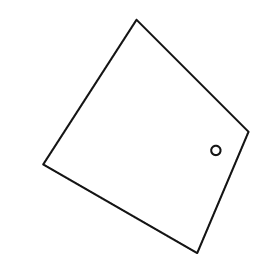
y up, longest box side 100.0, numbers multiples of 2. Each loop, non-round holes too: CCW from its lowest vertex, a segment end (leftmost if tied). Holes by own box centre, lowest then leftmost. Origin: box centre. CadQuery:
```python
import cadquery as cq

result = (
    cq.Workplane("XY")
    .moveTo(22.0, -50.0)
    .lineTo(44.0, 2.0)
    .lineTo(-4.0, 50.0)
    .lineTo(-44.0, -12.0)
    .close()
    .moveTo(30.0, -6.0)
    .circle(2.0)
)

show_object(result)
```